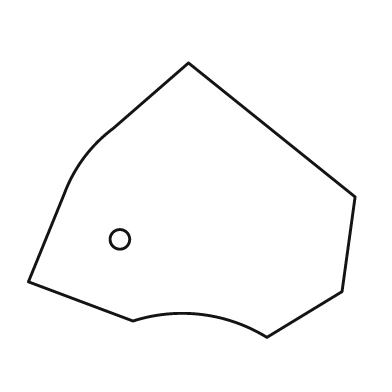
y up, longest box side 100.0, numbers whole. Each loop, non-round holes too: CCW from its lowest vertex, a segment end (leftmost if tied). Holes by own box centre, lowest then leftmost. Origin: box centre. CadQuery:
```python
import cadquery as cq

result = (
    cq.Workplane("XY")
    .moveTo(23.0, -42.0)
    .lineTo(46.0, -28.0)
    .lineTo(50.0, 1.0)
    .lineTo(-1.0, 42.0)
    .lineTo(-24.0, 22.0)
    .threePointArc((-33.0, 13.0), (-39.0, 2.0))
    .lineTo(-50.0, -25.0)
    .lineTo(-18.0, -37.0)
    .threePointArc((3.0, -35.0), (23.0, -42.0))
    .close()
    .moveTo(-22.0, -12.0)
    .circle(3.0)
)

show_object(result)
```